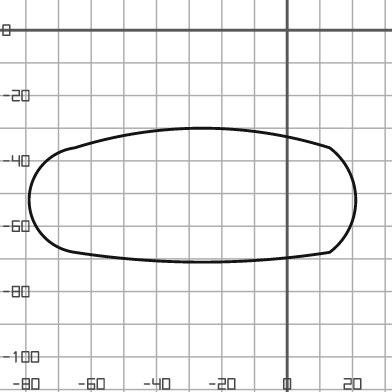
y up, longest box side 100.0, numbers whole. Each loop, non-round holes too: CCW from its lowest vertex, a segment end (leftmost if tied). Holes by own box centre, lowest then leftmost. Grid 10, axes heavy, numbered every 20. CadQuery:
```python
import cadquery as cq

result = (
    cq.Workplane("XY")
    .moveTo(-65.0, -68.0)
    .threePointArc((-26.0, -71.0), (13.0, -68.0))
    .threePointArc((21.0, -52.0), (13.0, -36.0))
    .threePointArc((-26.0, -30.0), (-65.0, -36.0))
    .threePointArc((-79.0, -52.0), (-65.0, -68.0))
    .close()
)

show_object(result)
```